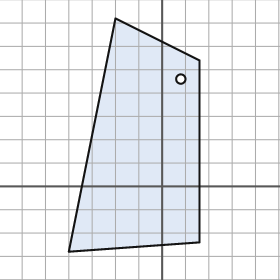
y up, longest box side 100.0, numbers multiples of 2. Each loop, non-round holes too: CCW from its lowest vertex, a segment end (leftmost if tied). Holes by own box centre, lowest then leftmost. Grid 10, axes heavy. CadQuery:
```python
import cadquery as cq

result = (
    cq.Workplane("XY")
    .moveTo(-40.0, -28.0)
    .lineTo(16.0, -24.0)
    .lineTo(16.0, 54.0)
    .lineTo(-20.0, 72.0)
    .close()
    .moveTo(8.0, 46.0)
    .circle(2.0)
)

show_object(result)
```